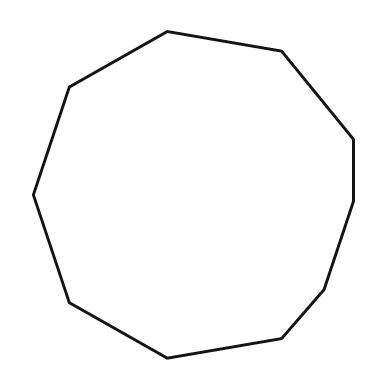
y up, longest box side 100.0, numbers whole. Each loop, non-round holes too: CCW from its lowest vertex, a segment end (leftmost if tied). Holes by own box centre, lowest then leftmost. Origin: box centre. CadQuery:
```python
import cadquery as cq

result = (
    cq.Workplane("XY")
    .moveTo(-8.0, -50.0)
    .lineTo(27.0, -44.0)
    .lineTo(40.0, -29.0)
    .lineTo(49.0, -2.0)
    .lineTo(49.0, 17.0)
    .lineTo(27.0, 44.0)
    .lineTo(-8.0, 50.0)
    .lineTo(-38.0, 33.0)
    .lineTo(-49.0, 0.0)
    .lineTo(-38.0, -33.0)
    .close()
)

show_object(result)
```